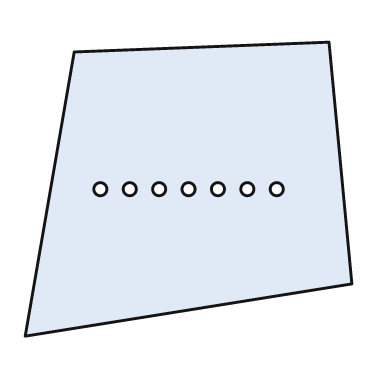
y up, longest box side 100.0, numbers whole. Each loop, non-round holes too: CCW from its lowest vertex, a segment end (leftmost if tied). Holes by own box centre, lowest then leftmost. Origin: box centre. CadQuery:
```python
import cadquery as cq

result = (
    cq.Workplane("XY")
    .moveTo(-50.0, -45.0)
    .lineTo(50.0, -29.0)
    .lineTo(43.0, 45.0)
    .lineTo(-35.0, 42.0)
    .close()
    .moveTo(-27.0, 0.0)
    .circle(2.0)
    .moveTo(-18.0, 0.0)
    .circle(2.0)
    .moveTo(-9.0, 0.0)
    .circle(2.0)
    .moveTo(0.0, 0.0)
    .circle(2.0)
    .moveTo(9.0, 0.0)
    .circle(2.0)
    .moveTo(18.0, 0.0)
    .circle(2.0)
    .moveTo(27.0, 0.0)
    .circle(2.0)
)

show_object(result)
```